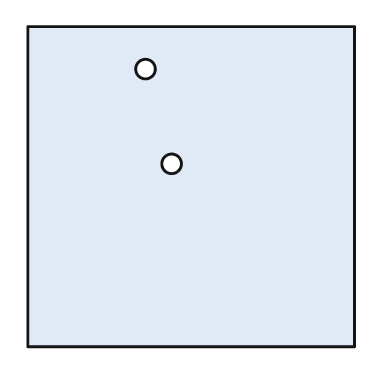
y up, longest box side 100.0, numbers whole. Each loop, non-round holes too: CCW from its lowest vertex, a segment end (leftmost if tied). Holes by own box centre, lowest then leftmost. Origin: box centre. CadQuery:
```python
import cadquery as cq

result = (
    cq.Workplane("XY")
    .moveTo(-50.0, -49.0)
    .lineTo(50.0, -49.0)
    .lineTo(50.0, 49.0)
    .lineTo(-50.0, 49.0)
    .close()
    .moveTo(-6.0, 7.0)
    .circle(3.0)
    .moveTo(-14.0, 36.0)
    .circle(3.0)
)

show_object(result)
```